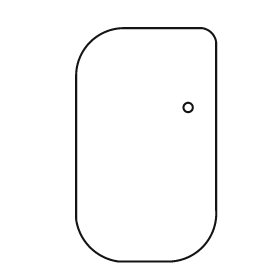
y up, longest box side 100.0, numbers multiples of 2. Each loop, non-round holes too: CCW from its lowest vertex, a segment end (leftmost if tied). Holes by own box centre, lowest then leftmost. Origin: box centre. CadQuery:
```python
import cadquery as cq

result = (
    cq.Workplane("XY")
    .moveTo(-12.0, -50.0)
    .lineTo(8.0, -50.0)
    .threePointArc((24.0, -44.0), (30.0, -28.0))
    .lineTo(30.0, 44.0)
    .threePointArc((28.0, 48.0), (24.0, 50.0))
    .lineTo(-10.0, 50.0)
    .threePointArc((-24.0, 44.0), (-30.0, 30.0))
    .lineTo(-30.0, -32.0)
    .threePointArc((-24.0, -44.0), (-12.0, -50.0))
    .close()
    .moveTo(18.0, 16.0)
    .circle(2.0)
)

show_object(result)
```